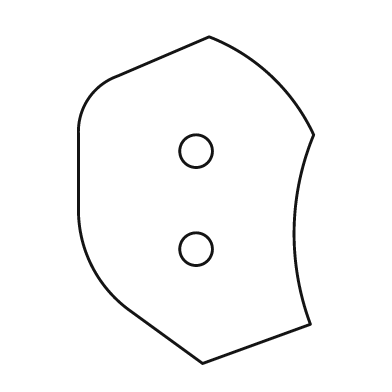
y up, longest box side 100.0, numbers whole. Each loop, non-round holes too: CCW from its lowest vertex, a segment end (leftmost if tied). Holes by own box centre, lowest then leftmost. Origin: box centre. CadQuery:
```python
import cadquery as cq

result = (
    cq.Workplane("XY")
    .moveTo(2.0, -50.0)
    .lineTo(35.0, -38.0)
    .threePointArc((30.0, -9.0), (36.0, 20.0))
    .threePointArc((23.0, 38.0), (4.0, 50.0))
    .lineTo(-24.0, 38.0)
    .threePointArc((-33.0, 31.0), (-36.0, 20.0))
    .lineTo(-36.0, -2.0)
    .threePointArc((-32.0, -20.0), (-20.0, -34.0))
    .close()
    .moveTo(0.0, -15.0)
    .circle(5.0)
    .moveTo(0.0, 15.0)
    .circle(5.0)
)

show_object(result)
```